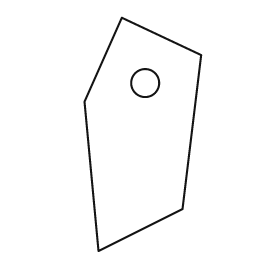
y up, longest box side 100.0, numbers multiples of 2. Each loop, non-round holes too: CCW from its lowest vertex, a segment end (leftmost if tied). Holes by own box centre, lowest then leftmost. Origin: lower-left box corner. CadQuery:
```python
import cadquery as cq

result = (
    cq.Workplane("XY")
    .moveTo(6.0, 0.0)
    .lineTo(42.0, 18.0)
    .lineTo(50.0, 84.0)
    .lineTo(16.0, 100.0)
    .lineTo(0.0, 64.0)
    .close()
    .moveTo(26.0, 72.0)
    .circle(6.0)
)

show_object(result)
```